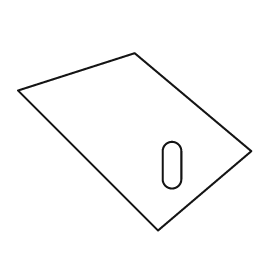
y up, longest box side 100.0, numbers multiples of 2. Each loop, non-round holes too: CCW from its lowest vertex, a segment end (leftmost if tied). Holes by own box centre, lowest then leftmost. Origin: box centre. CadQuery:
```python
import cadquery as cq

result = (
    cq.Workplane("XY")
    .moveTo(10.0, -38.0)
    .lineTo(50.0, -4.0)
    .lineTo(0.0, 38.0)
    .lineTo(-50.0, 22.0)
    .close()
    .moveTo(12.0, -16.0)
    .threePointArc((16.0, -20.0), (20.0, -16.0))
    .lineTo(20.0, -4.0)
    .threePointArc((16.0, 0.0), (12.0, -4.0))
    .close()
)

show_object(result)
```